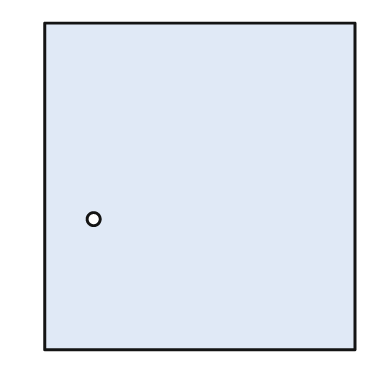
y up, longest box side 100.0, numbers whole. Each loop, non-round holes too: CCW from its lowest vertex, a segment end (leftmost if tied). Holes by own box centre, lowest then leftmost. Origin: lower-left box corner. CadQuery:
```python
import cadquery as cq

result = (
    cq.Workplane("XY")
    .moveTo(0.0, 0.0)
    .lineTo(95.0, 0.0)
    .lineTo(95.0, 100.0)
    .lineTo(0.0, 100.0)
    .close()
    .moveTo(15.0, 40.0)
    .circle(2.0)
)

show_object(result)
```